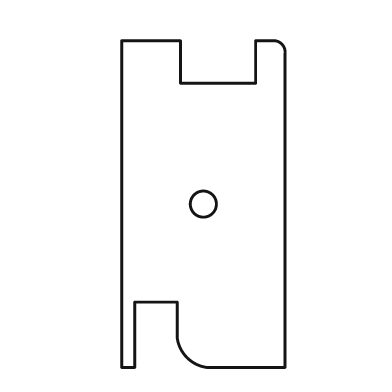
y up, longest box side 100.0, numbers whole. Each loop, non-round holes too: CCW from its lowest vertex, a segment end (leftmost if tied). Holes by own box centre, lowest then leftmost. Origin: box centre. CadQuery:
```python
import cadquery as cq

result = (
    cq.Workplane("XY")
    .moveTo(-25.0, -50.0)
    .lineTo(-21.0, -50.0)
    .lineTo(-21.0, -30.0)
    .lineTo(-8.0, -30.0)
    .lineTo(-8.0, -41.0)
    .threePointArc((-5.0, -47.0), (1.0, -50.0))
    .lineTo(25.0, -50.0)
    .lineTo(25.0, 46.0)
    .threePointArc((24.0, 49.0), (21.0, 50.0))
    .lineTo(16.0, 50.0)
    .lineTo(16.0, 37.0)
    .lineTo(-7.0, 37.0)
    .lineTo(-7.0, 50.0)
    .lineTo(-25.0, 50.0)
    .close()
    .moveTo(0.0, 0.0)
    .circle(4.0)
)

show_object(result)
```